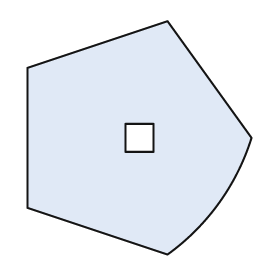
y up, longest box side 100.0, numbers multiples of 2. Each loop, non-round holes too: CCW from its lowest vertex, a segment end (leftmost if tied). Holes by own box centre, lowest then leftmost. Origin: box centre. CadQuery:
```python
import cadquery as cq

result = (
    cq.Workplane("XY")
    .moveTo(12.0, -50.0)
    .threePointArc((34.0, -28.0), (48.0, 0.0))
    .lineTo(12.0, 50.0)
    .lineTo(-48.0, 30.0)
    .lineTo(-48.0, -30.0)
    .close()
    .moveTo(-6.0, -6.0)
    .lineTo(6.0, -6.0)
    .lineTo(6.0, 6.0)
    .lineTo(-6.0, 6.0)
    .close()
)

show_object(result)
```